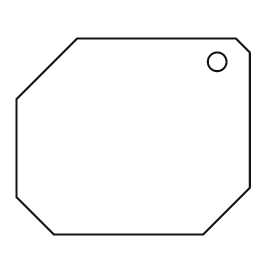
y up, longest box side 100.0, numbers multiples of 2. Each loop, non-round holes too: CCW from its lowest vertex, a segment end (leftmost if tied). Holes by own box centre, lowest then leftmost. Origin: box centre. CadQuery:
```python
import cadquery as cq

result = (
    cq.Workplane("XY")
    .moveTo(-34.0, -42.0)
    .lineTo(30.0, -42.0)
    .lineTo(50.0, -22.0)
    .lineTo(50.0, 36.0)
    .lineTo(44.0, 42.0)
    .lineTo(-24.0, 42.0)
    .lineTo(-50.0, 16.0)
    .lineTo(-50.0, -26.0)
    .close()
    .moveTo(36.0, 32.0)
    .circle(4.0)
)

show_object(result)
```